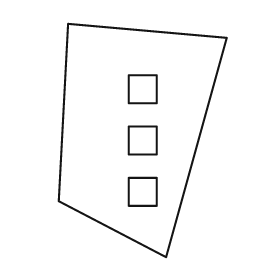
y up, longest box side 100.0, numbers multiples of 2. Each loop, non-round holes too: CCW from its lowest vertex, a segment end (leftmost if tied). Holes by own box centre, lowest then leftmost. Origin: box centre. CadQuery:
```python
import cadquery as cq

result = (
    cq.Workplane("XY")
    .moveTo(10.0, -50.0)
    .lineTo(36.0, 44.0)
    .lineTo(-32.0, 50.0)
    .lineTo(-36.0, -26.0)
    .close()
    .moveTo(-6.0, -28.0)
    .lineTo(6.0, -28.0)
    .lineTo(6.0, -16.0)
    .lineTo(-6.0, -16.0)
    .close()
    .moveTo(-6.0, -6.0)
    .lineTo(6.0, -6.0)
    .lineTo(6.0, 6.0)
    .lineTo(-6.0, 6.0)
    .close()
    .moveTo(-6.0, 16.0)
    .lineTo(6.0, 16.0)
    .lineTo(6.0, 28.0)
    .lineTo(-6.0, 28.0)
    .close()
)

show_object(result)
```